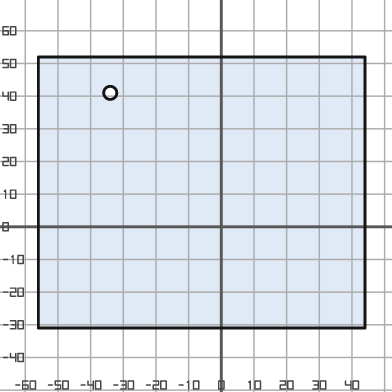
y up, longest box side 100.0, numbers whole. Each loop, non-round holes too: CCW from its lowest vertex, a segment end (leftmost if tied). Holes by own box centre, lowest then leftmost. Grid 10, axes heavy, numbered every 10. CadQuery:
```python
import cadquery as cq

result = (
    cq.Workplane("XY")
    .moveTo(-56.0, -31.0)
    .lineTo(44.0, -31.0)
    .lineTo(44.0, 52.0)
    .lineTo(-56.0, 52.0)
    .close()
    .moveTo(-34.0, 41.0)
    .circle(2.0)
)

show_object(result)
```